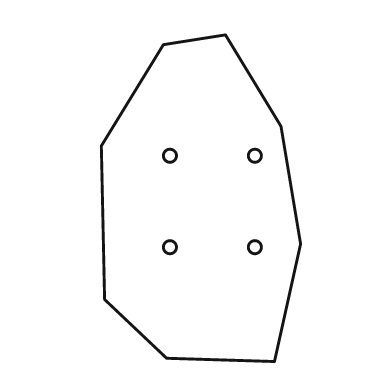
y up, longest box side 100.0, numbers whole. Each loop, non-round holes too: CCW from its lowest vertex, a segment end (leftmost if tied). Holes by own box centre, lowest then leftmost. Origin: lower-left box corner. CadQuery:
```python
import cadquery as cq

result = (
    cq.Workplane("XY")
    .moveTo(53.0, 0.0)
    .lineTo(61.0, 36.0)
    .lineTo(55.0, 72.0)
    .lineTo(38.0, 100.0)
    .lineTo(19.0, 97.0)
    .lineTo(0.0, 66.0)
    .lineTo(1.0, 19.0)
    .lineTo(20.0, 1.0)
    .close()
    .moveTo(21.0, 35.0)
    .circle(2.0)
    .moveTo(47.0, 35.0)
    .circle(2.0)
    .moveTo(21.0, 63.0)
    .circle(2.0)
    .moveTo(47.0, 63.0)
    .circle(2.0)
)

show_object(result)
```